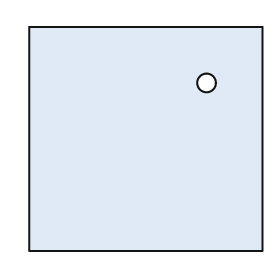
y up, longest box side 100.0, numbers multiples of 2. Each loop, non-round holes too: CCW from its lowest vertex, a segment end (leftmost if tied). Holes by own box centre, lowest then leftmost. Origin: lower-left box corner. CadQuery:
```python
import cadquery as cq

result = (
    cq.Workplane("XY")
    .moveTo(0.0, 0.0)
    .lineTo(100.0, 0.0)
    .lineTo(100.0, 96.0)
    .lineTo(0.0, 96.0)
    .close()
    .moveTo(76.0, 72.0)
    .circle(4.0)
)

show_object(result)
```